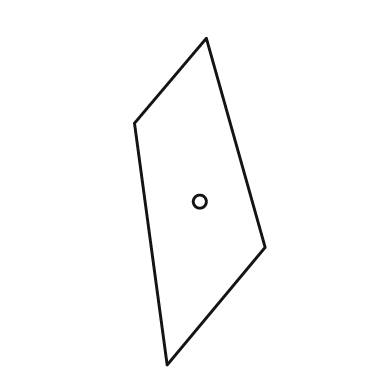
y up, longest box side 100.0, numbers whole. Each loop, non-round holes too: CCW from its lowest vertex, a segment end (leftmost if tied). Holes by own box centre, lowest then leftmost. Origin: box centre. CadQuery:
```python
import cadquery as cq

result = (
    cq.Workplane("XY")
    .moveTo(-10.0, -50.0)
    .lineTo(20.0, -14.0)
    .lineTo(2.0, 50.0)
    .lineTo(-20.0, 24.0)
    .close()
    .moveTo(0.0, 0.0)
    .circle(2.0)
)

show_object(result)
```